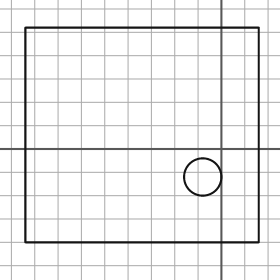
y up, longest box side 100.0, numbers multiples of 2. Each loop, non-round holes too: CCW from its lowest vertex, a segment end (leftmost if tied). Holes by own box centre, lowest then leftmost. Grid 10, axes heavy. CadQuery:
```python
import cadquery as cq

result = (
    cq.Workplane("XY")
    .moveTo(-84.0, -40.0)
    .lineTo(16.0, -40.0)
    .lineTo(16.0, 52.0)
    .lineTo(-84.0, 52.0)
    .close()
    .moveTo(-8.0, -12.0)
    .circle(8.0)
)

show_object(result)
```